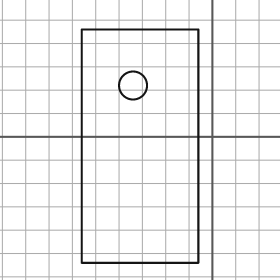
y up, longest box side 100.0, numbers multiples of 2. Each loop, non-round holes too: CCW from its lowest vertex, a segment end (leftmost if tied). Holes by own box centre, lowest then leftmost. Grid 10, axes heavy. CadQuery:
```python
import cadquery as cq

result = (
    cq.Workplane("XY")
    .moveTo(-56.0, -54.0)
    .lineTo(-6.0, -54.0)
    .lineTo(-6.0, 46.0)
    .lineTo(-56.0, 46.0)
    .close()
    .moveTo(-34.0, 22.0)
    .circle(6.0)
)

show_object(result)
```